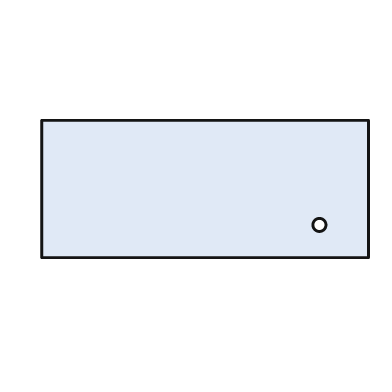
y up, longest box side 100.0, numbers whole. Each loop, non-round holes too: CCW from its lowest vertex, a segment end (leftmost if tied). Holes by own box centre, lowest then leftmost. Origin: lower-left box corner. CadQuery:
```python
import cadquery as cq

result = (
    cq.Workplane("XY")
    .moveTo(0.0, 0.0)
    .lineTo(100.0, 0.0)
    .lineTo(100.0, 42.0)
    .lineTo(0.0, 42.0)
    .close()
    .moveTo(85.0, 10.0)
    .circle(2.0)
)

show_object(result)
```